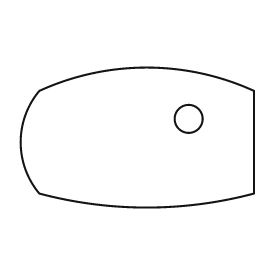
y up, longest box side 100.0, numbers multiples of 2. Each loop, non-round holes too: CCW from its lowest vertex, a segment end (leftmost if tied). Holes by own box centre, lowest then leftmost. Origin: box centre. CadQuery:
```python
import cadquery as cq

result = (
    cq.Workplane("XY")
    .moveTo(-42.0, -24.0)
    .threePointArc((4.0, -30.0), (50.0, -24.0))
    .lineTo(50.0, 20.0)
    .threePointArc((4.0, 30.0), (-42.0, 20.0))
    .threePointArc((-50.0, -2.0), (-42.0, -24.0))
    .close()
    .moveTo(22.0, 8.0)
    .circle(6.0)
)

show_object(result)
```